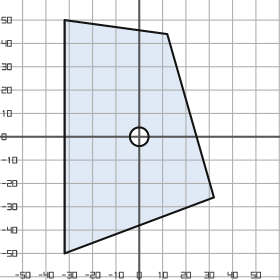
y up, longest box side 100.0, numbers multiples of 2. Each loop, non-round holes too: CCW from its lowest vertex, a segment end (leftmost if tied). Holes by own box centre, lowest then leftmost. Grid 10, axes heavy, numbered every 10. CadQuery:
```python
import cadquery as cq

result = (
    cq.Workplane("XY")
    .moveTo(-32.0, -50.0)
    .lineTo(32.0, -26.0)
    .lineTo(12.0, 44.0)
    .lineTo(-32.0, 50.0)
    .close()
    .moveTo(0.0, 0.0)
    .circle(4.0)
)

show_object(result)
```